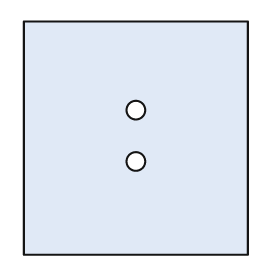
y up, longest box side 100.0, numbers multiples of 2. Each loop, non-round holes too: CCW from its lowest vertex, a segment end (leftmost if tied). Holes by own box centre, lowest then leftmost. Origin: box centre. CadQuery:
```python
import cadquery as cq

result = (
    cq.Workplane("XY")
    .moveTo(-48.0, -50.0)
    .lineTo(48.0, -50.0)
    .lineTo(48.0, 50.0)
    .lineTo(-48.0, 50.0)
    .close()
    .moveTo(0.0, -10.0)
    .circle(4.0)
    .moveTo(0.0, 12.0)
    .circle(4.0)
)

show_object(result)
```